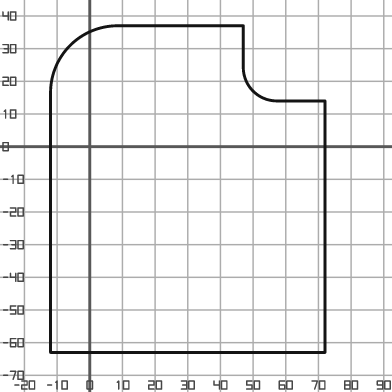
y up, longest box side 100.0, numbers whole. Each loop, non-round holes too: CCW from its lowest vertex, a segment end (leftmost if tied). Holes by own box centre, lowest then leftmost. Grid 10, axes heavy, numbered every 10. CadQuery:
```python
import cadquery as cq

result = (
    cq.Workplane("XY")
    .moveTo(-12.0, -63.0)
    .lineTo(72.0, -63.0)
    .lineTo(72.0, 14.0)
    .lineTo(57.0, 14.0)
    .threePointArc((50.0, 17.0), (47.0, 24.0))
    .lineTo(47.0, 37.0)
    .lineTo(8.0, 37.0)
    .threePointArc((-6.0, 31.0), (-12.0, 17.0))
    .close()
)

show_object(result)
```